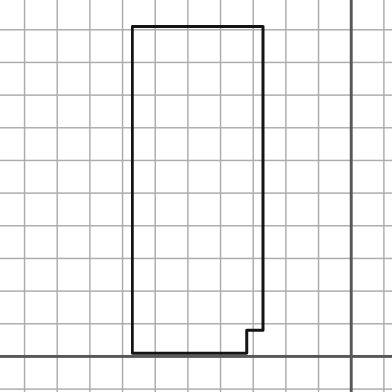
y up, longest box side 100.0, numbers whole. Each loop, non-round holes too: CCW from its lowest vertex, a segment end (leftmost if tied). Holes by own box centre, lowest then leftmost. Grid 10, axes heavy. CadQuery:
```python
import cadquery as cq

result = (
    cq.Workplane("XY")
    .moveTo(-67.0, 1.0)
    .lineTo(-32.0, 1.0)
    .lineTo(-32.0, 8.0)
    .lineTo(-27.0, 8.0)
    .lineTo(-27.0, 101.0)
    .lineTo(-67.0, 101.0)
    .close()
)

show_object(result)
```